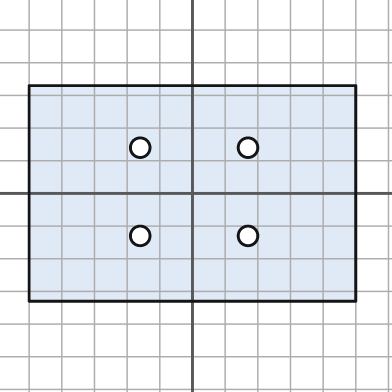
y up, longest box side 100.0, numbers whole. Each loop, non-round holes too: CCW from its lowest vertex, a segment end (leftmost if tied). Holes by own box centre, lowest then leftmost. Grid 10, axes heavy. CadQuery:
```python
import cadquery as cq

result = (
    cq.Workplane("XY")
    .moveTo(-50.0, -33.0)
    .lineTo(50.0, -33.0)
    .lineTo(50.0, 33.0)
    .lineTo(-50.0, 33.0)
    .close()
    .moveTo(-16.0, -13.0)
    .circle(3.0)
    .moveTo(17.0, -13.0)
    .circle(3.0)
    .moveTo(-16.0, 14.0)
    .circle(3.0)
    .moveTo(17.0, 14.0)
    .circle(3.0)
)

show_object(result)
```